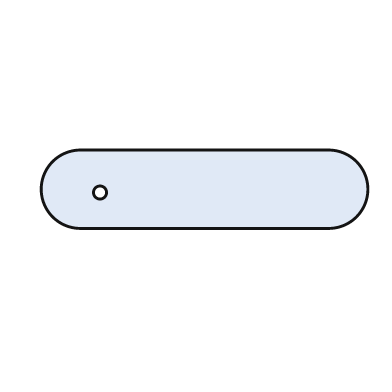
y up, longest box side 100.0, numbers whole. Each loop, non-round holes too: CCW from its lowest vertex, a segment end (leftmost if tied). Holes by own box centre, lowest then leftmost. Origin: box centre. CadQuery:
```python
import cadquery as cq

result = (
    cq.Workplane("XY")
    .moveTo(-38.0, -12.0)
    .lineTo(38.0, -12.0)
    .threePointArc((50.0, 0.0), (38.0, 12.0))
    .lineTo(-38.0, 12.0)
    .threePointArc((-50.0, 0.0), (-38.0, -12.0))
    .close()
    .moveTo(-32.0, -1.0)
    .circle(2.0)
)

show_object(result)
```